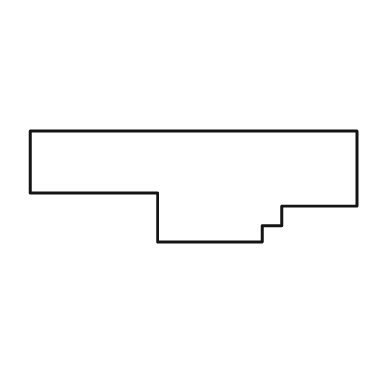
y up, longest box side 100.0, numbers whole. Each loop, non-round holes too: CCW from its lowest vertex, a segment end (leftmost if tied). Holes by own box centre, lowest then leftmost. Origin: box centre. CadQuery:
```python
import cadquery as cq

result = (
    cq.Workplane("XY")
    .moveTo(-11.0, -17.0)
    .lineTo(21.0, -17.0)
    .lineTo(21.0, -12.0)
    .lineTo(27.0, -12.0)
    .lineTo(27.0, -6.0)
    .lineTo(50.0, -6.0)
    .lineTo(50.0, 17.0)
    .lineTo(-50.0, 17.0)
    .lineTo(-50.0, -2.0)
    .lineTo(-11.0, -2.0)
    .close()
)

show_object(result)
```